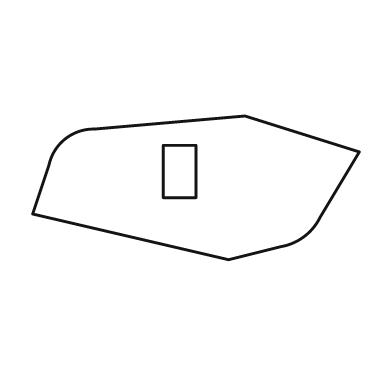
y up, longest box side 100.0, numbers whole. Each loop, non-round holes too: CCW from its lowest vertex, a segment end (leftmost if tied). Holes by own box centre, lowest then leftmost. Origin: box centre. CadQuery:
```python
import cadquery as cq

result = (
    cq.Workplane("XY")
    .moveTo(10.0, -22.0)
    .lineTo(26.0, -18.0)
    .threePointArc((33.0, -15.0), (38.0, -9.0))
    .lineTo(50.0, 11.0)
    .lineTo(15.0, 22.0)
    .lineTo(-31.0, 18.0)
    .threePointArc((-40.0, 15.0), (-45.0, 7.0))
    .lineTo(-50.0, -8.0)
    .close()
    .moveTo(-10.0, -3.0)
    .lineTo(0.0, -3.0)
    .lineTo(0.0, 13.0)
    .lineTo(-10.0, 13.0)
    .close()
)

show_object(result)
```